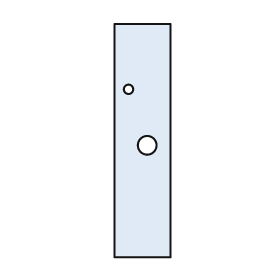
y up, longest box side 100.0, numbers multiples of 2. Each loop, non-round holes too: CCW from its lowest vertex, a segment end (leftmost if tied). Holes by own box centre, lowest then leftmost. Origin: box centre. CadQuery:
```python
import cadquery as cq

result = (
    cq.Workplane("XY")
    .moveTo(-12.0, -50.0)
    .lineTo(12.0, -50.0)
    .lineTo(12.0, 50.0)
    .lineTo(-12.0, 50.0)
    .close()
    .moveTo(2.0, -2.0)
    .circle(4.0)
    .moveTo(-6.0, 22.0)
    .circle(2.0)
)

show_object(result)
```